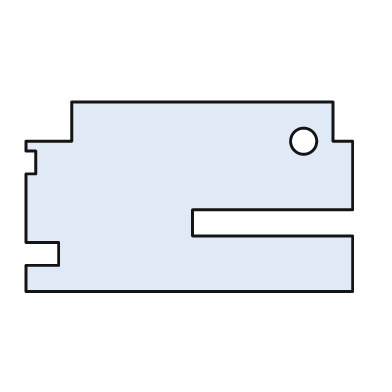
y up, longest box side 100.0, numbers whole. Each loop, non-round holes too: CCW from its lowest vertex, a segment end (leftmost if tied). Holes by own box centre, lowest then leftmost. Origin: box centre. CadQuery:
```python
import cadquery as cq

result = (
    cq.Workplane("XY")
    .moveTo(-50.0, -29.0)
    .lineTo(50.0, -29.0)
    .lineTo(50.0, -12.0)
    .lineTo(1.0, -12.0)
    .lineTo(1.0, -4.0)
    .lineTo(50.0, -4.0)
    .lineTo(50.0, 17.0)
    .lineTo(44.0, 17.0)
    .lineTo(44.0, 29.0)
    .lineTo(-36.0, 29.0)
    .lineTo(-36.0, 17.0)
    .lineTo(-50.0, 17.0)
    .lineTo(-50.0, 14.0)
    .lineTo(-47.0, 14.0)
    .lineTo(-47.0, 7.0)
    .lineTo(-50.0, 7.0)
    .lineTo(-50.0, -14.0)
    .lineTo(-40.0, -14.0)
    .lineTo(-40.0, -21.0)
    .lineTo(-50.0, -21.0)
    .close()
    .moveTo(35.0, 17.0)
    .circle(4.0)
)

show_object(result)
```